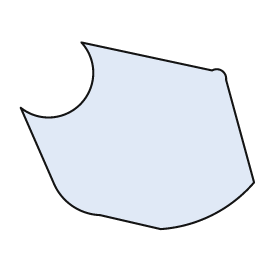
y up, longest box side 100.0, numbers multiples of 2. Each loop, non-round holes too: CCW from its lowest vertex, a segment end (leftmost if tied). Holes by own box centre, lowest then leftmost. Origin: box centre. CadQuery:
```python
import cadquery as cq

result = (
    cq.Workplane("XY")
    .moveTo(10.0, -40.0)
    .threePointArc((32.0, -34.0), (50.0, -20.0))
    .lineTo(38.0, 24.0)
    .threePointArc((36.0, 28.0), (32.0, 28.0))
    .lineTo(-24.0, 40.0)
    .threePointArc((-24.0, 14.0), (-50.0, 12.0))
    .lineTo(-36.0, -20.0)
    .threePointArc((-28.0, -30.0), (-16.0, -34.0))
    .close()
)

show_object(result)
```